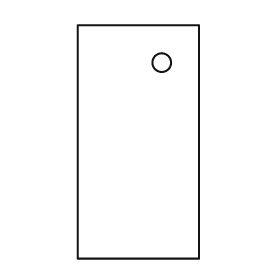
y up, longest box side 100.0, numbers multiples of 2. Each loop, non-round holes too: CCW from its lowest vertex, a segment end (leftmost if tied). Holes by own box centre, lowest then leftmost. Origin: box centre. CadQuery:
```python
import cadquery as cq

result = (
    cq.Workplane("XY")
    .moveTo(-26.0, -50.0)
    .lineTo(26.0, -50.0)
    .lineTo(26.0, 50.0)
    .lineTo(-26.0, 50.0)
    .close()
    .moveTo(10.0, 34.0)
    .circle(4.0)
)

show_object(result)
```